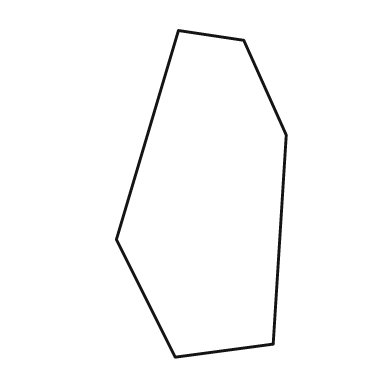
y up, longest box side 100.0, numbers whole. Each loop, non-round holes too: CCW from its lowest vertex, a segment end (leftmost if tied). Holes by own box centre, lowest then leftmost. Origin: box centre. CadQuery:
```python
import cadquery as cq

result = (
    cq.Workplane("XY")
    .moveTo(-8.0, -50.0)
    .lineTo(22.0, -46.0)
    .lineTo(26.0, 18.0)
    .lineTo(13.0, 47.0)
    .lineTo(-7.0, 50.0)
    .lineTo(-26.0, -14.0)
    .close()
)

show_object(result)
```